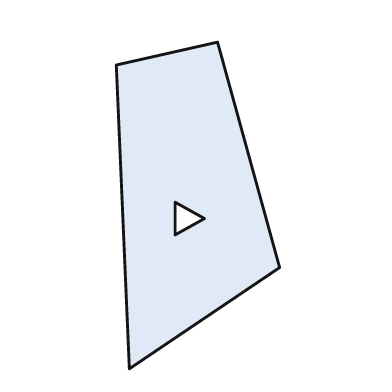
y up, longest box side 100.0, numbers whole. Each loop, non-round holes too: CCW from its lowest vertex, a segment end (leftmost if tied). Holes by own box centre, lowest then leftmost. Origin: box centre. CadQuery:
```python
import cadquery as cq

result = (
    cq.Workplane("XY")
    .moveTo(-21.0, -50.0)
    .lineTo(25.0, -19.0)
    .lineTo(6.0, 50.0)
    .lineTo(-25.0, 43.0)
    .close()
    .moveTo(-7.0, -9.0)
    .lineTo(2.0, -4.0)
    .lineTo(-7.0, 1.0)
    .close()
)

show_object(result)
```